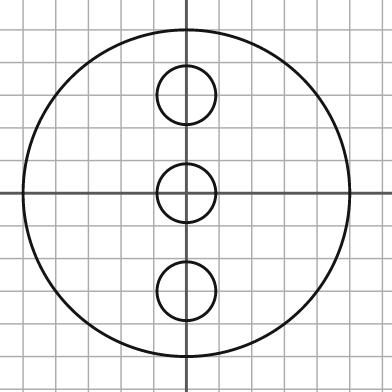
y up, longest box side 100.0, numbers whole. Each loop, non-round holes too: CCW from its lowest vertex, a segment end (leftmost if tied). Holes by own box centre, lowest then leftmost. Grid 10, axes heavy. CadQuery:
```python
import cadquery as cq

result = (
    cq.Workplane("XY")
    .moveTo(0.0, 0.0)
    .circle(50.0)
    .moveTo(0.0, -30.0)
    .circle(9.0)
    .moveTo(0.0, 0.0)
    .circle(9.0)
    .moveTo(0.0, 30.0)
    .circle(9.0)
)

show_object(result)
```